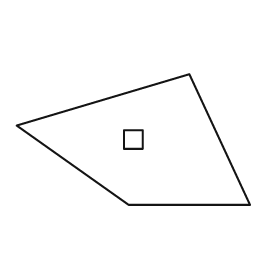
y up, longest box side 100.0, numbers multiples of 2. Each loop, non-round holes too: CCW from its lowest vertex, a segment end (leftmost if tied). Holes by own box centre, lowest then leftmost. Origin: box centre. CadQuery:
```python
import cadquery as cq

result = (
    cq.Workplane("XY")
    .moveTo(-2.0, -28.0)
    .lineTo(50.0, -28.0)
    .lineTo(24.0, 28.0)
    .lineTo(-50.0, 6.0)
    .close()
    .moveTo(-4.0, -4.0)
    .lineTo(4.0, -4.0)
    .lineTo(4.0, 4.0)
    .lineTo(-4.0, 4.0)
    .close()
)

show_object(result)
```